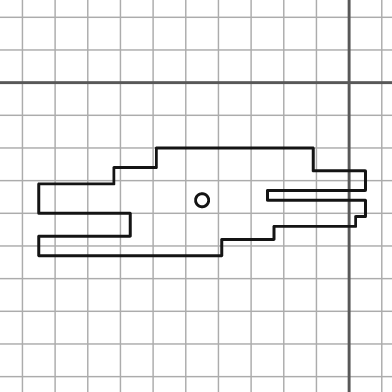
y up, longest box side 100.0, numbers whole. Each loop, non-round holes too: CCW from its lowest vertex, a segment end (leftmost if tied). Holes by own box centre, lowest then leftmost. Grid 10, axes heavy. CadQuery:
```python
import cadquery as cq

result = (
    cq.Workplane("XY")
    .moveTo(-95.0, -53.0)
    .lineTo(-39.0, -53.0)
    .lineTo(-39.0, -48.0)
    .lineTo(-23.0, -48.0)
    .lineTo(-23.0, -44.0)
    .lineTo(2.0, -44.0)
    .lineTo(2.0, -41.0)
    .lineTo(5.0, -41.0)
    .lineTo(5.0, -36.0)
    .lineTo(-25.0, -36.0)
    .lineTo(-25.0, -33.0)
    .lineTo(5.0, -33.0)
    .lineTo(5.0, -27.0)
    .lineTo(-11.0, -27.0)
    .lineTo(-11.0, -20.0)
    .lineTo(-59.0, -20.0)
    .lineTo(-59.0, -26.0)
    .lineTo(-72.0, -26.0)
    .lineTo(-72.0, -31.0)
    .lineTo(-95.0, -31.0)
    .lineTo(-95.0, -40.0)
    .lineTo(-67.0, -40.0)
    .lineTo(-67.0, -47.0)
    .lineTo(-95.0, -47.0)
    .close()
    .moveTo(-45.0, -36.0)
    .circle(2.0)
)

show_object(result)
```